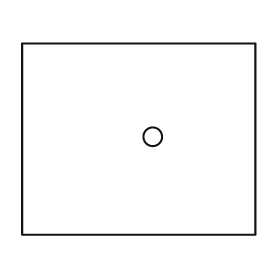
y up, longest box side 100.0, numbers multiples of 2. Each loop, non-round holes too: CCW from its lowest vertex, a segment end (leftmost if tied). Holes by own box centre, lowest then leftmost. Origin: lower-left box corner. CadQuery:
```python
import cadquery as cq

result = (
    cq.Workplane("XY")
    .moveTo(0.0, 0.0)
    .lineTo(100.0, 0.0)
    .lineTo(100.0, 82.0)
    .lineTo(0.0, 82.0)
    .close()
    .moveTo(56.0, 42.0)
    .circle(4.0)
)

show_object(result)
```